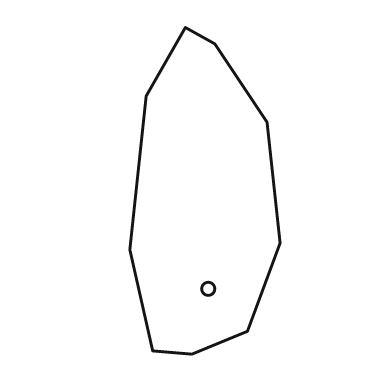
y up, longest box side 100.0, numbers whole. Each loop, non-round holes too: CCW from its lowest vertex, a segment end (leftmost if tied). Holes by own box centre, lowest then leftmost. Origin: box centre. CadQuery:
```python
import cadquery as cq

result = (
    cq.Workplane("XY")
    .moveTo(-4.0, -50.0)
    .lineTo(13.0, -43.0)
    .lineTo(23.0, -16.0)
    .lineTo(19.0, 21.0)
    .lineTo(3.0, 45.0)
    .lineTo(-6.0, 50.0)
    .lineTo(-18.0, 29.0)
    .lineTo(-23.0, -18.0)
    .lineTo(-16.0, -49.0)
    .close()
    .moveTo(1.0, -30.0)
    .circle(2.0)
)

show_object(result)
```